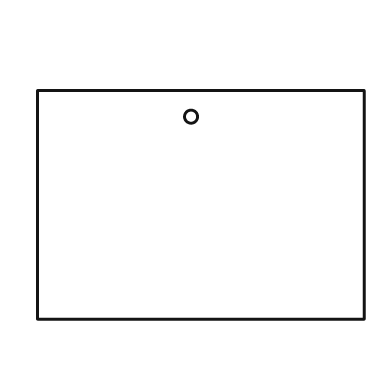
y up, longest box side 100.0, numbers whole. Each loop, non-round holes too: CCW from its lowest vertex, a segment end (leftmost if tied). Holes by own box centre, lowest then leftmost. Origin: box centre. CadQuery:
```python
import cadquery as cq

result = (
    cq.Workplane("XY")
    .moveTo(-50.0, -35.0)
    .lineTo(50.0, -35.0)
    .lineTo(50.0, 35.0)
    .lineTo(-50.0, 35.0)
    .close()
    .moveTo(-3.0, 27.0)
    .circle(2.0)
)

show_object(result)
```